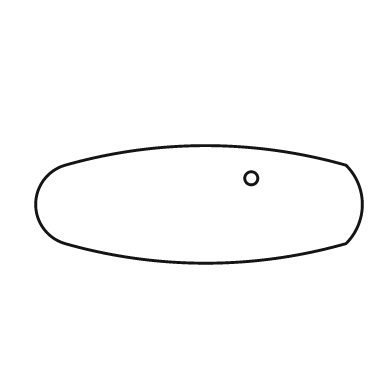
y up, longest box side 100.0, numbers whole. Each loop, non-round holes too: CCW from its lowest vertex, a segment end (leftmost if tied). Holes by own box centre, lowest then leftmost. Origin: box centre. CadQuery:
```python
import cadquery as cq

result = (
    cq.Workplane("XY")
    .moveTo(-41.0, -12.0)
    .threePointArc((2.0, -18.0), (45.0, -12.0))
    .threePointArc((50.0, 0.0), (45.0, 12.0))
    .threePointArc((2.0, 18.0), (-41.0, 12.0))
    .threePointArc((-50.0, 0.0), (-41.0, -12.0))
    .close()
    .moveTo(16.0, 8.0)
    .circle(2.0)
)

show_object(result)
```